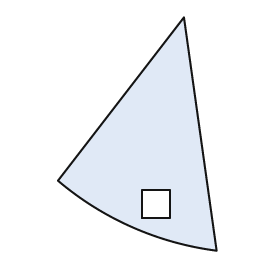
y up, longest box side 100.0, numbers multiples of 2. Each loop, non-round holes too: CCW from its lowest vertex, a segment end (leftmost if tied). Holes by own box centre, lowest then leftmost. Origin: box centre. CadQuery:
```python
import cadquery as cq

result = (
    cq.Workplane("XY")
    .moveTo(34.0, -50.0)
    .lineTo(20.0, 50.0)
    .lineTo(-34.0, -20.0)
    .threePointArc((-2.0, -40.0), (34.0, -50.0))
    .close()
    .moveTo(2.0, -36.0)
    .lineTo(14.0, -36.0)
    .lineTo(14.0, -24.0)
    .lineTo(2.0, -24.0)
    .close()
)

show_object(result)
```